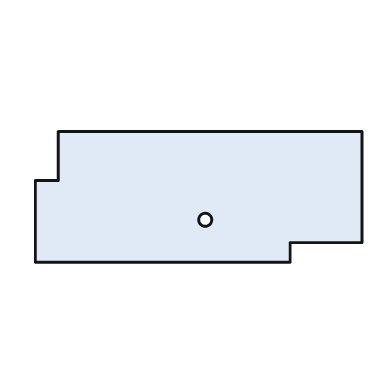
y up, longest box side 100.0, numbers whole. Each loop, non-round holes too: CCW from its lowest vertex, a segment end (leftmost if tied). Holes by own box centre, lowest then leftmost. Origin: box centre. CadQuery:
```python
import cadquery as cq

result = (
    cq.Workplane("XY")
    .moveTo(-50.0, -20.0)
    .lineTo(28.0, -20.0)
    .lineTo(28.0, -14.0)
    .lineTo(50.0, -14.0)
    .lineTo(50.0, 20.0)
    .lineTo(-43.0, 20.0)
    .lineTo(-43.0, 5.0)
    .lineTo(-50.0, 5.0)
    .close()
    .moveTo(2.0, -7.0)
    .circle(2.0)
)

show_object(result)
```